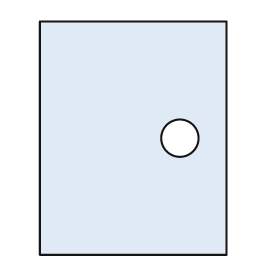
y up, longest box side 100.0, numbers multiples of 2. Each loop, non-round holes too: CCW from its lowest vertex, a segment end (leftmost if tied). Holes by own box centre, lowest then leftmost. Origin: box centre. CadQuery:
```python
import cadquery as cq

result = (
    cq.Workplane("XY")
    .moveTo(-40.0, -50.0)
    .lineTo(40.0, -50.0)
    .lineTo(40.0, 50.0)
    .lineTo(-40.0, 50.0)
    .close()
    .moveTo(20.0, 0.0)
    .circle(8.0)
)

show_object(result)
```